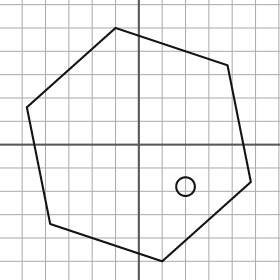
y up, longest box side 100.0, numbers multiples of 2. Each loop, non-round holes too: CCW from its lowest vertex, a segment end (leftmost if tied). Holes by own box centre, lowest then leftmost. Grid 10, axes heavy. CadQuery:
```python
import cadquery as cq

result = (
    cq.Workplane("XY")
    .moveTo(10.0, -50.0)
    .lineTo(48.0, -16.0)
    .lineTo(38.0, 34.0)
    .lineTo(-10.0, 50.0)
    .lineTo(-48.0, 16.0)
    .lineTo(-38.0, -34.0)
    .close()
    .moveTo(20.0, -18.0)
    .circle(4.0)
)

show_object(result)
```